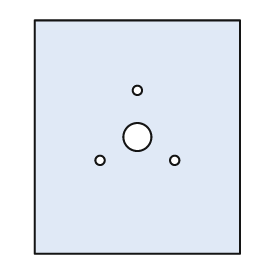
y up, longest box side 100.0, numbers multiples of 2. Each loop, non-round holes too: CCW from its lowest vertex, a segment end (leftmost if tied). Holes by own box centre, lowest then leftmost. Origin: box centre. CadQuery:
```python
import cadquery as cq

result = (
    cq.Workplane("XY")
    .moveTo(-44.0, -50.0)
    .lineTo(44.0, -50.0)
    .lineTo(44.0, 50.0)
    .lineTo(-44.0, 50.0)
    .close()
    .moveTo(-16.0, -10.0)
    .circle(2.0)
    .moveTo(16.0, -10.0)
    .circle(2.0)
    .moveTo(0.0, 0.0)
    .circle(6.0)
    .moveTo(0.0, 20.0)
    .circle(2.0)
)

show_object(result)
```